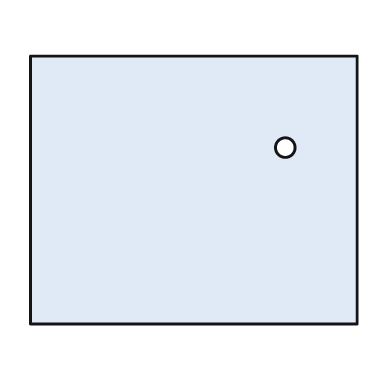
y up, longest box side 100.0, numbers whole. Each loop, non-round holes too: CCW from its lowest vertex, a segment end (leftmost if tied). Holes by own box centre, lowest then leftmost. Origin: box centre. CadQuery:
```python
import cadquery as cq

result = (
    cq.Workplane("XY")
    .moveTo(-50.0, -41.0)
    .lineTo(50.0, -41.0)
    .lineTo(50.0, 41.0)
    .lineTo(-50.0, 41.0)
    .close()
    .moveTo(28.0, 13.0)
    .circle(3.0)
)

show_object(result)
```